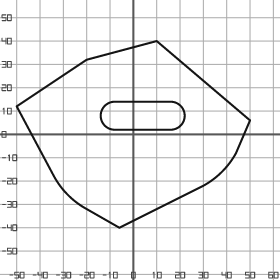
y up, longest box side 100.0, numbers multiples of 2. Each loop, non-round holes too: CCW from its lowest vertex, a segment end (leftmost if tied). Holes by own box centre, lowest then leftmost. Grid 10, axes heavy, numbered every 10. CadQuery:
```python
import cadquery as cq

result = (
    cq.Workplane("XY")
    .moveTo(-6.0, -40.0)
    .lineTo(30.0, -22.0)
    .threePointArc((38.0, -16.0), (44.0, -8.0))
    .lineTo(50.0, 6.0)
    .lineTo(10.0, 40.0)
    .lineTo(-20.0, 32.0)
    .lineTo(-50.0, 12.0)
    .lineTo(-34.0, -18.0)
    .threePointArc((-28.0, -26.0), (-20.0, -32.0))
    .close()
    .moveTo(-8.0, 2.0)
    .lineTo(16.0, 2.0)
    .threePointArc((22.0, 8.0), (16.0, 14.0))
    .lineTo(-8.0, 14.0)
    .threePointArc((-14.0, 8.0), (-8.0, 2.0))
    .close()
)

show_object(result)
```